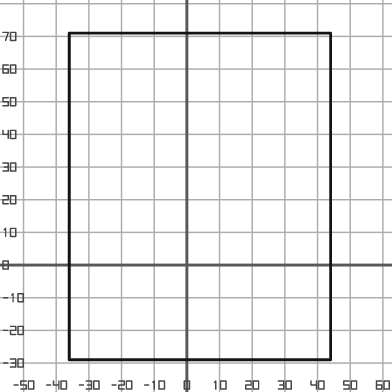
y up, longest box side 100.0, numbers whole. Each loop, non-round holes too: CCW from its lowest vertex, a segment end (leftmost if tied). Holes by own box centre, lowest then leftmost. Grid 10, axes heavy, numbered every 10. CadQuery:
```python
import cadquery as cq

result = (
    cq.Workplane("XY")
    .moveTo(-36.0, -29.0)
    .lineTo(44.0, -29.0)
    .lineTo(44.0, 71.0)
    .lineTo(-36.0, 71.0)
    .close()
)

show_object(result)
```